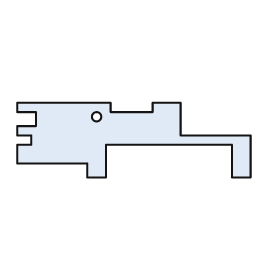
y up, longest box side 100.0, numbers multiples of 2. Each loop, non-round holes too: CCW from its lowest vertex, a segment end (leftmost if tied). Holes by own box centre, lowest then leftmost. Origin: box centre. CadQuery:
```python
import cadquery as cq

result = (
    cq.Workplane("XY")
    .moveTo(-20.0, -16.0)
    .lineTo(-12.0, -16.0)
    .lineTo(-12.0, -2.0)
    .lineTo(42.0, -2.0)
    .lineTo(42.0, -16.0)
    .lineTo(50.0, -16.0)
    .lineTo(50.0, 2.0)
    .lineTo(20.0, 2.0)
    .lineTo(20.0, 16.0)
    .lineTo(8.0, 16.0)
    .lineTo(8.0, 12.0)
    .lineTo(-10.0, 12.0)
    .lineTo(-10.0, 16.0)
    .lineTo(-50.0, 16.0)
    .lineTo(-50.0, 12.0)
    .lineTo(-42.0, 12.0)
    .lineTo(-42.0, 6.0)
    .lineTo(-50.0, 6.0)
    .lineTo(-50.0, 2.0)
    .lineTo(-44.0, 2.0)
    .lineTo(-44.0, -2.0)
    .lineTo(-50.0, -2.0)
    .lineTo(-50.0, -10.0)
    .lineTo(-20.0, -10.0)
    .close()
    .moveTo(-16.0, 10.0)
    .circle(2.0)
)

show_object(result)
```